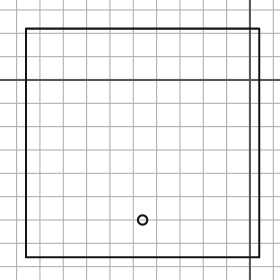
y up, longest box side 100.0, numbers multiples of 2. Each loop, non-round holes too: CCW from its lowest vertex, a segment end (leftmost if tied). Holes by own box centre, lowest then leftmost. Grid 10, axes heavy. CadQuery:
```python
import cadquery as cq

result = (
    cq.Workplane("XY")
    .moveTo(-96.0, -76.0)
    .lineTo(4.0, -76.0)
    .lineTo(4.0, 22.0)
    .lineTo(-96.0, 22.0)
    .close()
    .moveTo(-46.0, -60.0)
    .circle(2.0)
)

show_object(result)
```